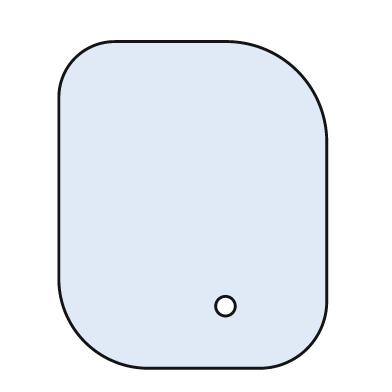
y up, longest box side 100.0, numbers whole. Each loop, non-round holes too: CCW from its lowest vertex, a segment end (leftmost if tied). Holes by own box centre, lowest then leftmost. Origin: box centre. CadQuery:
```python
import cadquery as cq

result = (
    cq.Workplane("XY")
    .moveTo(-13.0, -50.0)
    .lineTo(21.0, -50.0)
    .threePointArc((35.0, -44.0), (41.0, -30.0))
    .lineTo(41.0, 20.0)
    .threePointArc((32.0, 41.0), (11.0, 50.0))
    .lineTo(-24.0, 50.0)
    .threePointArc((-36.0, 45.0), (-41.0, 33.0))
    .lineTo(-41.0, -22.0)
    .threePointArc((-33.0, -42.0), (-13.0, -50.0))
    .close()
    .moveTo(10.0, -31.0)
    .circle(3.0)
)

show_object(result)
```